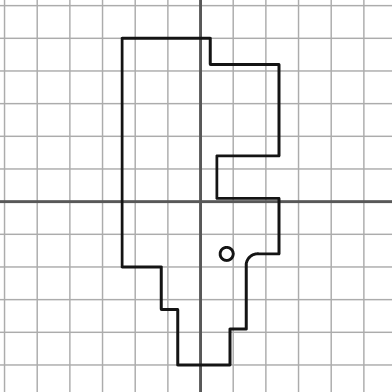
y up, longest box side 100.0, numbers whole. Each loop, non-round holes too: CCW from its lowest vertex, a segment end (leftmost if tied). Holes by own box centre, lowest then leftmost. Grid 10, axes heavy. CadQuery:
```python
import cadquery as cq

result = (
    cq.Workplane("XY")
    .moveTo(-7.0, -50.0)
    .lineTo(9.0, -50.0)
    .lineTo(9.0, -39.0)
    .lineTo(14.0, -39.0)
    .lineTo(14.0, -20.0)
    .threePointArc((15.0, -17.0), (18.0, -16.0))
    .lineTo(24.0, -16.0)
    .lineTo(24.0, 1.0)
    .lineTo(5.0, 1.0)
    .lineTo(5.0, 14.0)
    .lineTo(24.0, 14.0)
    .lineTo(24.0, 42.0)
    .lineTo(3.0, 42.0)
    .lineTo(3.0, 50.0)
    .lineTo(-24.0, 50.0)
    .lineTo(-24.0, -20.0)
    .lineTo(-12.0, -20.0)
    .lineTo(-12.0, -33.0)
    .lineTo(-7.0, -33.0)
    .close()
    .moveTo(8.0, -16.0)
    .circle(2.0)
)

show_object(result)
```